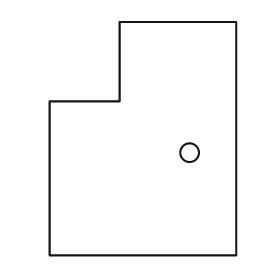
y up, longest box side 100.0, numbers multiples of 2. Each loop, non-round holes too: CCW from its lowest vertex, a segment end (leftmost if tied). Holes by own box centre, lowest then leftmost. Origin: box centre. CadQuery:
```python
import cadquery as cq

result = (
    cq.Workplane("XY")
    .moveTo(-40.0, -50.0)
    .lineTo(40.0, -50.0)
    .lineTo(40.0, 50.0)
    .lineTo(-10.0, 50.0)
    .lineTo(-10.0, 16.0)
    .lineTo(-40.0, 16.0)
    .close()
    .moveTo(20.0, -6.0)
    .circle(4.0)
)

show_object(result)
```